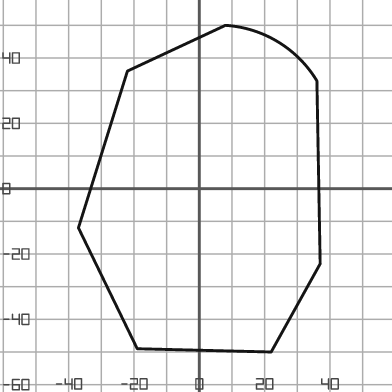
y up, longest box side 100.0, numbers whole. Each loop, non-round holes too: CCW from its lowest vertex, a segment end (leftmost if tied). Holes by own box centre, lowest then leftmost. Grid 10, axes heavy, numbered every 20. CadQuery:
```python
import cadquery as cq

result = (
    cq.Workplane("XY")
    .moveTo(22.0, -50.0)
    .lineTo(37.0, -23.0)
    .lineTo(36.0, 33.0)
    .threePointArc((24.0, 45.0), (8.0, 50.0))
    .lineTo(-22.0, 36.0)
    .lineTo(-37.0, -12.0)
    .lineTo(-19.0, -49.0)
    .close()
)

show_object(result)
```